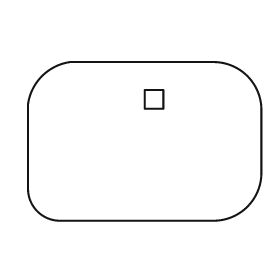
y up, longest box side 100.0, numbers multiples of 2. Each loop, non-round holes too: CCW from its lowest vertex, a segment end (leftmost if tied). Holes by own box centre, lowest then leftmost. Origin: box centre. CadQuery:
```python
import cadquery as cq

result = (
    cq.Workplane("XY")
    .moveTo(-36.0, -34.0)
    .lineTo(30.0, -34.0)
    .threePointArc((44.0, -28.0), (50.0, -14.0))
    .lineTo(50.0, 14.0)
    .threePointArc((44.0, 28.0), (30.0, 34.0))
    .lineTo(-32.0, 34.0)
    .threePointArc((-44.0, 28.0), (-50.0, 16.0))
    .lineTo(-50.0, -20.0)
    .threePointArc((-46.0, -30.0), (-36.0, -34.0))
    .close()
    .moveTo(0.0, 14.0)
    .lineTo(8.0, 14.0)
    .lineTo(8.0, 22.0)
    .lineTo(0.0, 22.0)
    .close()
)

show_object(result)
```